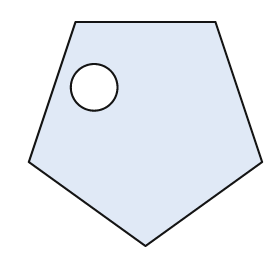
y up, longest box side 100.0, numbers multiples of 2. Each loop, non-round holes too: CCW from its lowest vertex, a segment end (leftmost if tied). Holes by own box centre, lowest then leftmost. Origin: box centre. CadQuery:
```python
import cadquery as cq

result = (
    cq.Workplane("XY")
    .moveTo(0.0, -48.0)
    .lineTo(50.0, -12.0)
    .lineTo(30.0, 48.0)
    .lineTo(-30.0, 48.0)
    .lineTo(-50.0, -12.0)
    .close()
    .moveTo(-22.0, 20.0)
    .circle(10.0)
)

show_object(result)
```